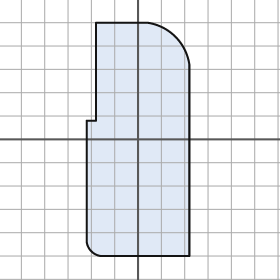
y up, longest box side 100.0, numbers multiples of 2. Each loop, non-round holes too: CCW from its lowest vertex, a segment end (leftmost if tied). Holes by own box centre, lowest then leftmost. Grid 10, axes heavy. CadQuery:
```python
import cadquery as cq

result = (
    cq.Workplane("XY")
    .moveTo(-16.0, -50.0)
    .lineTo(22.0, -50.0)
    .lineTo(22.0, 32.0)
    .threePointArc((16.0, 44.0), (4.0, 50.0))
    .lineTo(-18.0, 50.0)
    .lineTo(-18.0, 8.0)
    .lineTo(-22.0, 8.0)
    .lineTo(-22.0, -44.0)
    .threePointArc((-20.0, -48.0), (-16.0, -50.0))
    .close()
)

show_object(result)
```